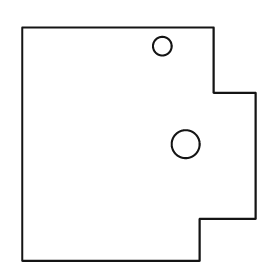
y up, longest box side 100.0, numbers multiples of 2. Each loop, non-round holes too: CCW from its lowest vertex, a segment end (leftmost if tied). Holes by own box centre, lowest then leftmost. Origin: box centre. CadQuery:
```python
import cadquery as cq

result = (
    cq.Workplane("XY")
    .moveTo(-50.0, -50.0)
    .lineTo(26.0, -50.0)
    .lineTo(26.0, -32.0)
    .lineTo(50.0, -32.0)
    .lineTo(50.0, 22.0)
    .lineTo(32.0, 22.0)
    .lineTo(32.0, 50.0)
    .lineTo(-50.0, 50.0)
    .close()
    .moveTo(20.0, 0.0)
    .circle(6.0)
    .moveTo(10.0, 42.0)
    .circle(4.0)
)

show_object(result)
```